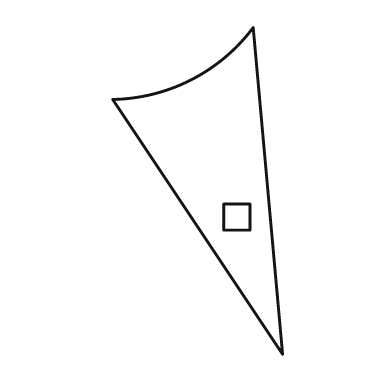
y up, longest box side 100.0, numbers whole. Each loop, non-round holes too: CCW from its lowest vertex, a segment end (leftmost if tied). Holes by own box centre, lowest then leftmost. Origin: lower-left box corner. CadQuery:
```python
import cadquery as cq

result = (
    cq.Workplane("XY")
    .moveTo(52.0, 0.0)
    .lineTo(43.0, 100.0)
    .threePointArc((24.0, 84.0), (0.0, 78.0))
    .close()
    .moveTo(34.0, 38.0)
    .lineTo(42.0, 38.0)
    .lineTo(42.0, 46.0)
    .lineTo(34.0, 46.0)
    .close()
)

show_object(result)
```